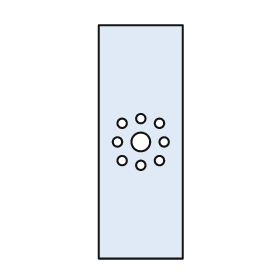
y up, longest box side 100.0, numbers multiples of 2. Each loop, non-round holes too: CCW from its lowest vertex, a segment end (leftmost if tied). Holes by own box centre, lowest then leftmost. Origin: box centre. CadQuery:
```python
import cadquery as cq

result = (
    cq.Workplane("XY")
    .moveTo(-18.0, -50.0)
    .lineTo(18.0, -50.0)
    .lineTo(18.0, 50.0)
    .lineTo(-18.0, 50.0)
    .close()
    .moveTo(0.0, -10.0)
    .circle(2.0)
    .moveTo(-8.0, -8.0)
    .circle(2.0)
    .moveTo(8.0, -8.0)
    .circle(2.0)
    .moveTo(-10.0, 0.0)
    .circle(2.0)
    .moveTo(0.0, 0.0)
    .circle(4.0)
    .moveTo(10.0, 0.0)
    .circle(2.0)
    .moveTo(-8.0, 8.0)
    .circle(2.0)
    .moveTo(8.0, 8.0)
    .circle(2.0)
    .moveTo(0.0, 10.0)
    .circle(2.0)
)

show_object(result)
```